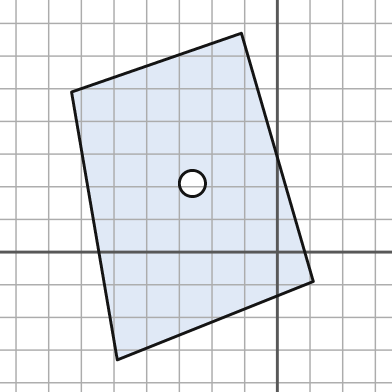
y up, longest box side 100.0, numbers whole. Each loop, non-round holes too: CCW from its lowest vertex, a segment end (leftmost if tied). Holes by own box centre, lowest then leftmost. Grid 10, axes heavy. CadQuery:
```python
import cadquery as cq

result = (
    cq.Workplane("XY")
    .moveTo(-49.0, -33.0)
    .lineTo(11.0, -9.0)
    .lineTo(-11.0, 67.0)
    .lineTo(-63.0, 49.0)
    .close()
    .moveTo(-26.0, 21.0)
    .circle(4.0)
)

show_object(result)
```